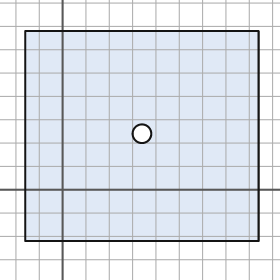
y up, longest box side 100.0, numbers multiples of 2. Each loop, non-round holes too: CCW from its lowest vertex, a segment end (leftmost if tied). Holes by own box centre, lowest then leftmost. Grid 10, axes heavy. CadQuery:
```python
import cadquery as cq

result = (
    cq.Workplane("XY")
    .moveTo(-16.0, -22.0)
    .lineTo(84.0, -22.0)
    .lineTo(84.0, 68.0)
    .lineTo(-16.0, 68.0)
    .close()
    .moveTo(34.0, 24.0)
    .circle(4.0)
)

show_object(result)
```